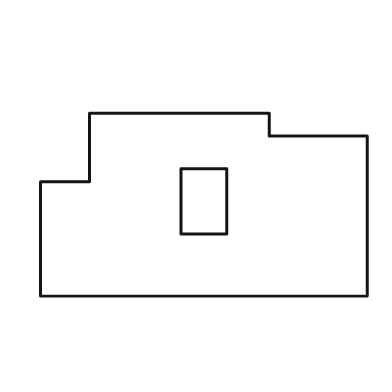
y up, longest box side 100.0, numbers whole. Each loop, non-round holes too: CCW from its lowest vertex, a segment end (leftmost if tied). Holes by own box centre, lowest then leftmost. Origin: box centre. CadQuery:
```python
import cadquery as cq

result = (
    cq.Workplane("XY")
    .moveTo(-50.0, -28.0)
    .lineTo(50.0, -28.0)
    .lineTo(50.0, 21.0)
    .lineTo(20.0, 21.0)
    .lineTo(20.0, 28.0)
    .lineTo(-35.0, 28.0)
    .lineTo(-35.0, 7.0)
    .lineTo(-50.0, 7.0)
    .close()
    .moveTo(-7.0, -9.0)
    .lineTo(7.0, -9.0)
    .lineTo(7.0, 11.0)
    .lineTo(-7.0, 11.0)
    .close()
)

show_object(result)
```